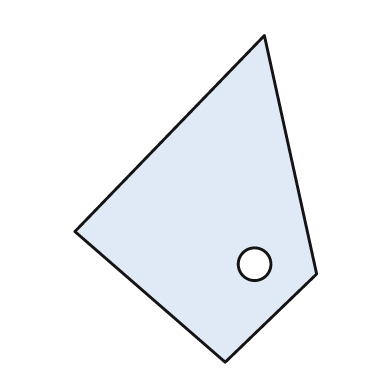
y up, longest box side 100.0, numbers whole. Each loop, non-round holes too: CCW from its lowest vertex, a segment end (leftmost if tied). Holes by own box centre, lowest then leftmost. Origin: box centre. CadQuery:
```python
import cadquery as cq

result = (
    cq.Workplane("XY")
    .moveTo(9.0, -50.0)
    .lineTo(37.0, -23.0)
    .lineTo(21.0, 50.0)
    .lineTo(-37.0, -10.0)
    .close()
    .moveTo(18.0, -20.0)
    .circle(5.0)
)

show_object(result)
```